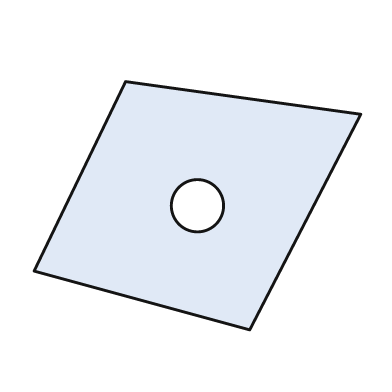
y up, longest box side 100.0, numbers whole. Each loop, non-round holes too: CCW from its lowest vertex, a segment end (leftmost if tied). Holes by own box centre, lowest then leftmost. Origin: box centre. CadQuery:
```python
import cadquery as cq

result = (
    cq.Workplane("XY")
    .moveTo(16.0, -38.0)
    .lineTo(50.0, 28.0)
    .lineTo(-22.0, 38.0)
    .lineTo(-50.0, -20.0)
    .close()
    .moveTo(0.0, 0.0)
    .circle(8.0)
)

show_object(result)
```